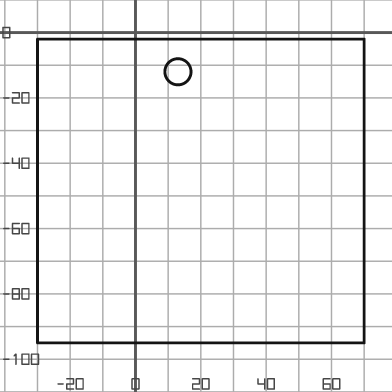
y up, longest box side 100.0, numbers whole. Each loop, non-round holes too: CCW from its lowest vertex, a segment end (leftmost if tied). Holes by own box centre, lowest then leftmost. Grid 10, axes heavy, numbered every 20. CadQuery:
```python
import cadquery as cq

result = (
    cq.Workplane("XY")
    .moveTo(-30.0, -95.0)
    .lineTo(70.0, -95.0)
    .lineTo(70.0, -2.0)
    .lineTo(-30.0, -2.0)
    .close()
    .moveTo(13.0, -12.0)
    .circle(4.0)
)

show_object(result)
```